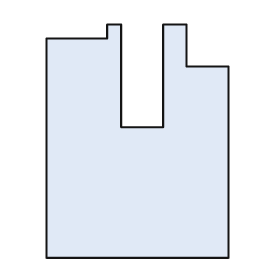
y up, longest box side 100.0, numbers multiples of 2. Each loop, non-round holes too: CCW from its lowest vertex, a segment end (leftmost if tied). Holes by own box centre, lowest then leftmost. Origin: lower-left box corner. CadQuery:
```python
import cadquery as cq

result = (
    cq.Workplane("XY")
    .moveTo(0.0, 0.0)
    .lineTo(78.0, 0.0)
    .lineTo(78.0, 82.0)
    .lineTo(60.0, 82.0)
    .lineTo(60.0, 100.0)
    .lineTo(50.0, 100.0)
    .lineTo(50.0, 56.0)
    .lineTo(32.0, 56.0)
    .lineTo(32.0, 100.0)
    .lineTo(26.0, 100.0)
    .lineTo(26.0, 94.0)
    .lineTo(0.0, 94.0)
    .close()
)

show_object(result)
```